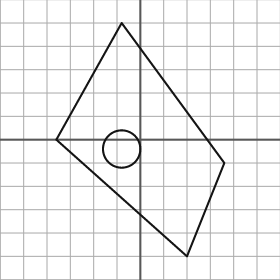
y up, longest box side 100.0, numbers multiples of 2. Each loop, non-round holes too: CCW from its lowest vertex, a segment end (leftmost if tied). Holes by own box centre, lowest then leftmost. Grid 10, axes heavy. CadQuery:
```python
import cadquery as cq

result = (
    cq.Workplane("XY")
    .moveTo(20.0, -50.0)
    .lineTo(36.0, -10.0)
    .lineTo(-8.0, 50.0)
    .lineTo(-36.0, 0.0)
    .close()
    .moveTo(-8.0, -4.0)
    .circle(8.0)
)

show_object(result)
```